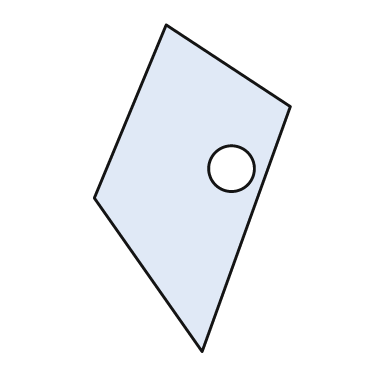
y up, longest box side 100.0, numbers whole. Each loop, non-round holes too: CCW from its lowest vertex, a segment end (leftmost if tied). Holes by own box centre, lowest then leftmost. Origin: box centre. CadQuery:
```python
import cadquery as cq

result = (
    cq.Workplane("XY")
    .moveTo(3.0, -50.0)
    .lineTo(30.0, 25.0)
    .lineTo(-8.0, 50.0)
    .lineTo(-30.0, -3.0)
    .close()
    .moveTo(12.0, 6.0)
    .circle(7.0)
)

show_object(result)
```